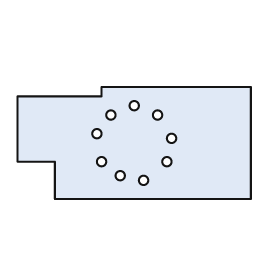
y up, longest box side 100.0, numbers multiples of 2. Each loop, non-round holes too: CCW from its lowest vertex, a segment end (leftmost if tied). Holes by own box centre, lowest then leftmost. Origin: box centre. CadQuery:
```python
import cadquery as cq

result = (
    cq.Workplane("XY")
    .moveTo(-34.0, -24.0)
    .lineTo(50.0, -24.0)
    .lineTo(50.0, 24.0)
    .lineTo(-14.0, 24.0)
    .lineTo(-14.0, 20.0)
    .lineTo(-50.0, 20.0)
    .lineTo(-50.0, -8.0)
    .lineTo(-34.0, -8.0)
    .close()
    .moveTo(4.0, -16.0)
    .circle(2.0)
    .moveTo(-6.0, -14.0)
    .circle(2.0)
    .moveTo(-14.0, -8.0)
    .circle(2.0)
    .moveTo(14.0, -8.0)
    .circle(2.0)
    .moveTo(16.0, 2.0)
    .circle(2.0)
    .moveTo(-16.0, 4.0)
    .circle(2.0)
    .moveTo(-10.0, 12.0)
    .circle(2.0)
    .moveTo(10.0, 12.0)
    .circle(2.0)
    .moveTo(0.0, 16.0)
    .circle(2.0)
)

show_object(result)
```